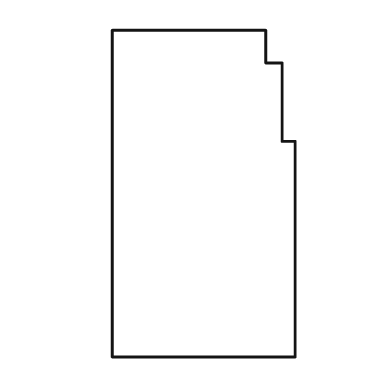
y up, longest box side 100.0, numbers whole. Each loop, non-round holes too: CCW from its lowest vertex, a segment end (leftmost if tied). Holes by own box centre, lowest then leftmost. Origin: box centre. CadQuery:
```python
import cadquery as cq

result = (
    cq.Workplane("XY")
    .moveTo(-28.0, -50.0)
    .lineTo(28.0, -50.0)
    .lineTo(28.0, 16.0)
    .lineTo(24.0, 16.0)
    .lineTo(24.0, 40.0)
    .lineTo(19.0, 40.0)
    .lineTo(19.0, 50.0)
    .lineTo(-28.0, 50.0)
    .close()
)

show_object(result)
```